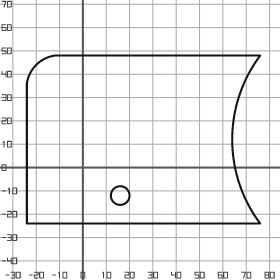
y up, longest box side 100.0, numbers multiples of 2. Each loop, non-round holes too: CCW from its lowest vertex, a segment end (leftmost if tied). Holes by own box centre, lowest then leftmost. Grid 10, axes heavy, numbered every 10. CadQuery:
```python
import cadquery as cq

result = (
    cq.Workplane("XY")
    .moveTo(-24.0, -24.0)
    .lineTo(76.0, -24.0)
    .threePointArc((64.0, 12.0), (76.0, 48.0))
    .lineTo(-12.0, 48.0)
    .threePointArc((-20.0, 44.0), (-24.0, 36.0))
    .close()
    .moveTo(16.0, -12.0)
    .circle(4.0)
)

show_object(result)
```